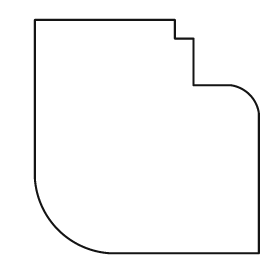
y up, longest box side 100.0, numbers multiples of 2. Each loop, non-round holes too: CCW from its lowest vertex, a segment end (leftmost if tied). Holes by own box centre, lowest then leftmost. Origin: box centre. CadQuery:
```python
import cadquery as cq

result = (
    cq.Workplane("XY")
    .moveTo(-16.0, -50.0)
    .lineTo(48.0, -50.0)
    .lineTo(48.0, 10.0)
    .threePointArc((44.0, 18.0), (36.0, 22.0))
    .lineTo(20.0, 22.0)
    .lineTo(20.0, 42.0)
    .lineTo(12.0, 42.0)
    .lineTo(12.0, 50.0)
    .lineTo(-48.0, 50.0)
    .lineTo(-48.0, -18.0)
    .threePointArc((-38.0, -40.0), (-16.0, -50.0))
    .close()
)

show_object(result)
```